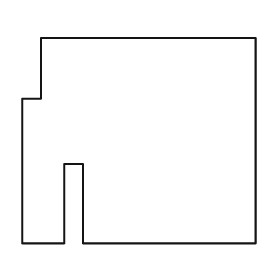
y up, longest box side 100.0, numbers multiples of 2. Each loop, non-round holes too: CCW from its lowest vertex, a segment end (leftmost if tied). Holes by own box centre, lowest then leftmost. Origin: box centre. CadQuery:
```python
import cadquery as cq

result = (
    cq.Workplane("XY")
    .moveTo(-50.0, -44.0)
    .lineTo(-32.0, -44.0)
    .lineTo(-32.0, -10.0)
    .lineTo(-24.0, -10.0)
    .lineTo(-24.0, -44.0)
    .lineTo(50.0, -44.0)
    .lineTo(50.0, 44.0)
    .lineTo(-42.0, 44.0)
    .lineTo(-42.0, 18.0)
    .lineTo(-50.0, 18.0)
    .close()
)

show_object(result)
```